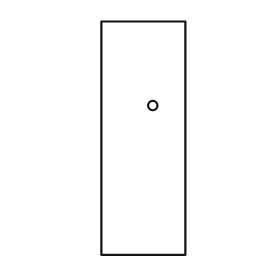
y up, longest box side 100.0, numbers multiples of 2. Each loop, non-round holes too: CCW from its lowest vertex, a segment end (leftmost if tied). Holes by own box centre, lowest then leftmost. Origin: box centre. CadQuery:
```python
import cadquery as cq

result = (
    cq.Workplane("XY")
    .moveTo(-18.0, -50.0)
    .lineTo(18.0, -50.0)
    .lineTo(18.0, 50.0)
    .lineTo(-18.0, 50.0)
    .close()
    .moveTo(4.0, 14.0)
    .circle(2.0)
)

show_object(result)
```